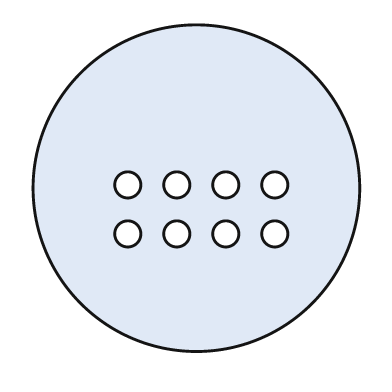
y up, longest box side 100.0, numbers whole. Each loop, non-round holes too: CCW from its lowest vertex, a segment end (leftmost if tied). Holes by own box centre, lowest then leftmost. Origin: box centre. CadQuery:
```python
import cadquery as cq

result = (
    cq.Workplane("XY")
    .moveTo(0.0, 0.0)
    .circle(50.0)
    .moveTo(-21.0, -14.0)
    .circle(4.0)
    .moveTo(-6.0, -14.0)
    .circle(4.0)
    .moveTo(9.0, -14.0)
    .circle(4.0)
    .moveTo(24.0, -14.0)
    .circle(4.0)
    .moveTo(-21.0, 1.0)
    .circle(4.0)
    .moveTo(-6.0, 1.0)
    .circle(4.0)
    .moveTo(9.0, 1.0)
    .circle(4.0)
    .moveTo(24.0, 1.0)
    .circle(4.0)
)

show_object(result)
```